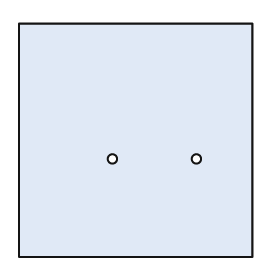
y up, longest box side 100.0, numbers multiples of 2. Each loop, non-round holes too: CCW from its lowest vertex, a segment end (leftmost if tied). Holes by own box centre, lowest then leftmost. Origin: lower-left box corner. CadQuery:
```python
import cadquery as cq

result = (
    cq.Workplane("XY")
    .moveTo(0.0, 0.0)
    .lineTo(100.0, 0.0)
    .lineTo(100.0, 100.0)
    .lineTo(0.0, 100.0)
    .close()
    .moveTo(40.0, 42.0)
    .circle(2.0)
    .moveTo(76.0, 42.0)
    .circle(2.0)
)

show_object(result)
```